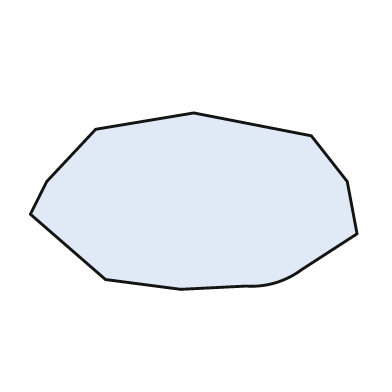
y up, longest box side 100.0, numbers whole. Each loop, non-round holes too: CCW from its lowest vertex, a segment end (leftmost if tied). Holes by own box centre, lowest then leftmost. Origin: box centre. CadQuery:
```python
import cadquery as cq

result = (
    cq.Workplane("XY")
    .moveTo(-4.0, -27.0)
    .lineTo(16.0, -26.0)
    .threePointArc((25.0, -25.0), (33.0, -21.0))
    .lineTo(50.0, -10.0)
    .lineTo(47.0, 6.0)
    .lineTo(36.0, 20.0)
    .lineTo(0.0, 27.0)
    .lineTo(-30.0, 22.0)
    .lineTo(-45.0, 6.0)
    .lineTo(-50.0, -4.0)
    .lineTo(-27.0, -24.0)
    .close()
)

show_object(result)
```